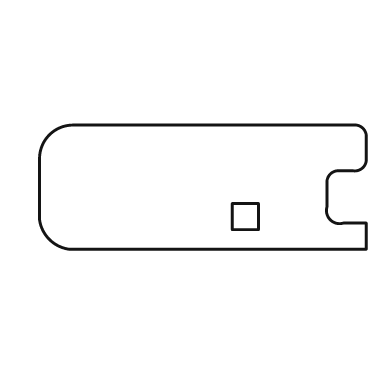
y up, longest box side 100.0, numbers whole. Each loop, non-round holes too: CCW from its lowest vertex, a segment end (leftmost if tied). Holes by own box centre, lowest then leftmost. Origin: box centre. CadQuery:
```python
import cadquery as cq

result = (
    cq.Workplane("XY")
    .moveTo(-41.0, -19.0)
    .lineTo(50.0, -19.0)
    .lineTo(50.0, -11.0)
    .lineTo(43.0, -11.0)
    .threePointArc((39.0, -10.0), (38.0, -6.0))
    .lineTo(38.0, 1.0)
    .threePointArc((39.0, 4.0), (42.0, 5.0))
    .lineTo(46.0, 5.0)
    .threePointArc((49.0, 6.0), (50.0, 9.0))
    .lineTo(50.0, 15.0)
    .threePointArc((49.0, 18.0), (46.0, 19.0))
    .lineTo(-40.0, 19.0)
    .threePointArc((-47.0, 16.0), (-50.0, 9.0))
    .lineTo(-50.0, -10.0)
    .threePointArc((-47.0, -16.0), (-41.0, -19.0))
    .close()
    .moveTo(9.0, -13.0)
    .lineTo(17.0, -13.0)
    .lineTo(17.0, -5.0)
    .lineTo(9.0, -5.0)
    .close()
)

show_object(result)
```